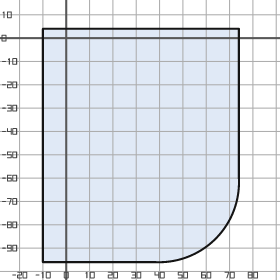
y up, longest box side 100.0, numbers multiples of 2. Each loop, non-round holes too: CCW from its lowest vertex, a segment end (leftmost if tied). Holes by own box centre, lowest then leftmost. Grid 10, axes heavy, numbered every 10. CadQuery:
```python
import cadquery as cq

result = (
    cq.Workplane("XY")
    .moveTo(-10.0, -96.0)
    .lineTo(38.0, -96.0)
    .threePointArc((64.0, -86.0), (74.0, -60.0))
    .lineTo(74.0, 4.0)
    .lineTo(-10.0, 4.0)
    .close()
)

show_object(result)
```